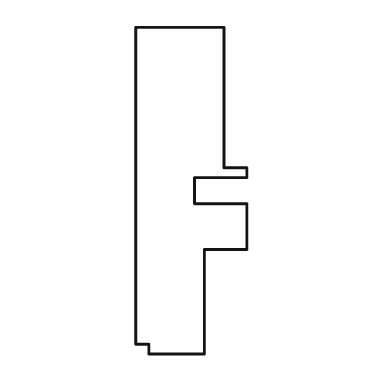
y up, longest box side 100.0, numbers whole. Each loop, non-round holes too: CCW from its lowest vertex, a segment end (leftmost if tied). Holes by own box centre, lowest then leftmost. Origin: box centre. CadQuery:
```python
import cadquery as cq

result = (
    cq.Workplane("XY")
    .moveTo(-13.0, -50.0)
    .lineTo(4.0, -50.0)
    .lineTo(4.0, -18.0)
    .lineTo(17.0, -18.0)
    .lineTo(17.0, -4.0)
    .lineTo(1.0, -4.0)
    .lineTo(1.0, 4.0)
    .lineTo(17.0, 4.0)
    .lineTo(17.0, 7.0)
    .lineTo(10.0, 7.0)
    .lineTo(10.0, 50.0)
    .lineTo(-17.0, 50.0)
    .lineTo(-17.0, -47.0)
    .lineTo(-13.0, -47.0)
    .close()
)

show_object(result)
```